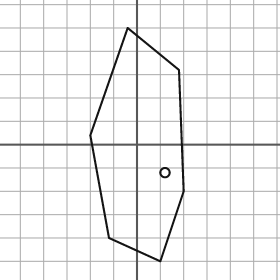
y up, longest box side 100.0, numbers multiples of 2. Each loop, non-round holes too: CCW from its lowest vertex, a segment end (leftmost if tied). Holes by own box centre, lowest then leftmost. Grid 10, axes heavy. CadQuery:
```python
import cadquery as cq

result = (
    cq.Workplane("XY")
    .moveTo(10.0, -50.0)
    .lineTo(20.0, -20.0)
    .lineTo(18.0, 32.0)
    .lineTo(-4.0, 50.0)
    .lineTo(-20.0, 4.0)
    .lineTo(-12.0, -40.0)
    .close()
    .moveTo(12.0, -12.0)
    .circle(2.0)
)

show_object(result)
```